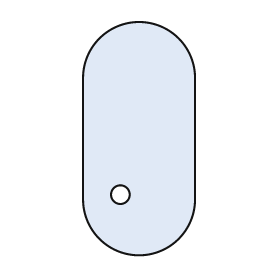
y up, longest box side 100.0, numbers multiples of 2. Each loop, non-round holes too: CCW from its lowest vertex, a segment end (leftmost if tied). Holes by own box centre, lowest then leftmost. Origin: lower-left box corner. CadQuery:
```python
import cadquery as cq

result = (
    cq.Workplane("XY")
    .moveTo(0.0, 24.0)
    .threePointArc((24.0, 0.0), (48.0, 24.0))
    .lineTo(48.0, 76.0)
    .threePointArc((24.0, 100.0), (0.0, 76.0))
    .close()
    .moveTo(16.0, 26.0)
    .circle(4.0)
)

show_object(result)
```